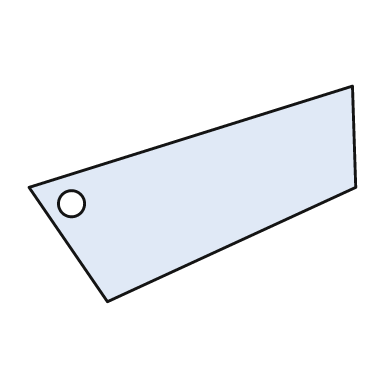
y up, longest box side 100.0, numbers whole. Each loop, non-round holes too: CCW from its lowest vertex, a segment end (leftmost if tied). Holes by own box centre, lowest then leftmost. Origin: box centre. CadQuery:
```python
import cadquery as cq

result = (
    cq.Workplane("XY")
    .moveTo(-26.0, -33.0)
    .lineTo(50.0, 2.0)
    .lineTo(49.0, 33.0)
    .lineTo(-50.0, 2.0)
    .close()
    .moveTo(-37.0, -3.0)
    .circle(4.0)
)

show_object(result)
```